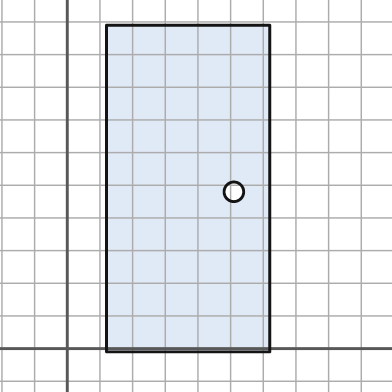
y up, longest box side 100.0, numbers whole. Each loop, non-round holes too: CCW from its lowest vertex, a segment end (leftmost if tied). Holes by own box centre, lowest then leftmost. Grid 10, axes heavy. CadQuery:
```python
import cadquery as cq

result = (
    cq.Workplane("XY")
    .moveTo(12.0, -1.0)
    .lineTo(62.0, -1.0)
    .lineTo(62.0, 99.0)
    .lineTo(12.0, 99.0)
    .close()
    .moveTo(51.0, 48.0)
    .circle(3.0)
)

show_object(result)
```